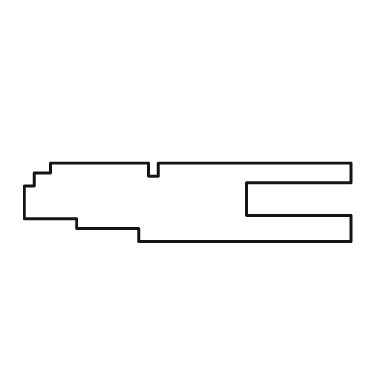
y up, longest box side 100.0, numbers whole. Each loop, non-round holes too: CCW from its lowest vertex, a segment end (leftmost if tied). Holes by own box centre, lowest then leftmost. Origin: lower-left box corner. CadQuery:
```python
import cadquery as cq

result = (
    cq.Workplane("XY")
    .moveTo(35.0, 0.0)
    .lineTo(100.0, 0.0)
    .lineTo(100.0, 8.0)
    .lineTo(68.0, 8.0)
    .lineTo(68.0, 18.0)
    .lineTo(100.0, 18.0)
    .lineTo(100.0, 24.0)
    .lineTo(41.0, 24.0)
    .lineTo(41.0, 20.0)
    .lineTo(38.0, 20.0)
    .lineTo(38.0, 24.0)
    .lineTo(8.0, 24.0)
    .lineTo(8.0, 21.0)
    .lineTo(3.0, 21.0)
    .lineTo(3.0, 17.0)
    .lineTo(0.0, 17.0)
    .lineTo(0.0, 7.0)
    .lineTo(16.0, 7.0)
    .lineTo(16.0, 4.0)
    .lineTo(35.0, 4.0)
    .close()
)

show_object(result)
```